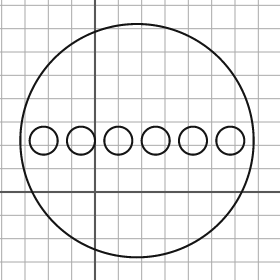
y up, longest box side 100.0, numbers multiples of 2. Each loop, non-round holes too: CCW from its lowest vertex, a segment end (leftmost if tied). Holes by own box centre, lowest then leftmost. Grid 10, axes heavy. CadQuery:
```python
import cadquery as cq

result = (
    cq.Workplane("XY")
    .moveTo(18.0, 22.0)
    .circle(50.0)
    .moveTo(-22.0, 22.0)
    .circle(6.0)
    .moveTo(-6.0, 22.0)
    .circle(6.0)
    .moveTo(10.0, 22.0)
    .circle(6.0)
    .moveTo(26.0, 22.0)
    .circle(6.0)
    .moveTo(42.0, 22.0)
    .circle(6.0)
    .moveTo(58.0, 22.0)
    .circle(6.0)
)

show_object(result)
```